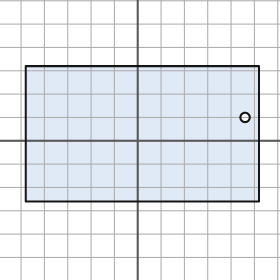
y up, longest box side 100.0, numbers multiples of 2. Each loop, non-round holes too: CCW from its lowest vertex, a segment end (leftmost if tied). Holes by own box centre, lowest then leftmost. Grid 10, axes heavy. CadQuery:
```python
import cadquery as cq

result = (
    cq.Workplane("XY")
    .moveTo(-48.0, -26.0)
    .lineTo(52.0, -26.0)
    .lineTo(52.0, 32.0)
    .lineTo(-48.0, 32.0)
    .close()
    .moveTo(46.0, 10.0)
    .circle(2.0)
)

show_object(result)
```